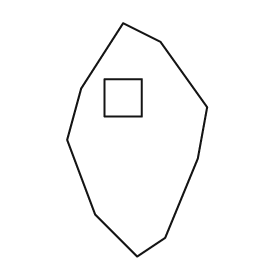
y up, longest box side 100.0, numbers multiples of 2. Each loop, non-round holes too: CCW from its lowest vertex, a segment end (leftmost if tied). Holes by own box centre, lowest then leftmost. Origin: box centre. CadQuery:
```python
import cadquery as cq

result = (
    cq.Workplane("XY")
    .moveTo(0.0, -50.0)
    .lineTo(12.0, -42.0)
    .lineTo(26.0, -8.0)
    .lineTo(30.0, 14.0)
    .lineTo(10.0, 42.0)
    .lineTo(-6.0, 50.0)
    .lineTo(-24.0, 22.0)
    .lineTo(-30.0, 0.0)
    .lineTo(-18.0, -32.0)
    .close()
    .moveTo(-14.0, 10.0)
    .lineTo(2.0, 10.0)
    .lineTo(2.0, 26.0)
    .lineTo(-14.0, 26.0)
    .close()
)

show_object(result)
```